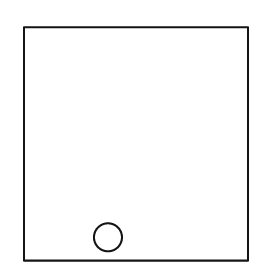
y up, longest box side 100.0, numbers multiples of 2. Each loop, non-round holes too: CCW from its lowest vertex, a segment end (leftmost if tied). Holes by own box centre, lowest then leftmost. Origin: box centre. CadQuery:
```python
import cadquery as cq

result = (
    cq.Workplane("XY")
    .moveTo(-48.0, -50.0)
    .lineTo(48.0, -50.0)
    .lineTo(48.0, 50.0)
    .lineTo(-48.0, 50.0)
    .close()
    .moveTo(-12.0, -40.0)
    .circle(6.0)
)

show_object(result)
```